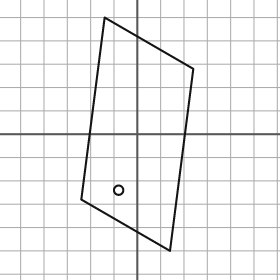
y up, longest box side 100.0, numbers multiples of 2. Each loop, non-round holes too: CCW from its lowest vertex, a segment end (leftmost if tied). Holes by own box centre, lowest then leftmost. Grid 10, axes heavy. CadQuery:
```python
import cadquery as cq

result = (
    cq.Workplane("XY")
    .moveTo(14.0, -50.0)
    .lineTo(24.0, 28.0)
    .lineTo(-14.0, 50.0)
    .lineTo(-24.0, -28.0)
    .close()
    .moveTo(-8.0, -24.0)
    .circle(2.0)
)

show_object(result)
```